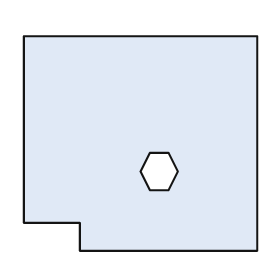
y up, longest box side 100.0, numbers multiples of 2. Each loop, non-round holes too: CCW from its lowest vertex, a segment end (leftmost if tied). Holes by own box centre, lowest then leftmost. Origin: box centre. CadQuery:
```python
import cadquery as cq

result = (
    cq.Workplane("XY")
    .moveTo(-26.0, -46.0)
    .lineTo(50.0, -46.0)
    .lineTo(50.0, 46.0)
    .lineTo(-50.0, 46.0)
    .lineTo(-50.0, -34.0)
    .lineTo(-26.0, -34.0)
    .close()
    .moveTo(4.0, -20.0)
    .lineTo(12.0, -20.0)
    .lineTo(16.0, -12.0)
    .lineTo(12.0, -4.0)
    .lineTo(4.0, -4.0)
    .lineTo(0.0, -12.0)
    .close()
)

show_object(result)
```